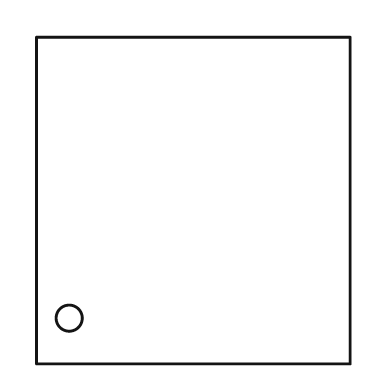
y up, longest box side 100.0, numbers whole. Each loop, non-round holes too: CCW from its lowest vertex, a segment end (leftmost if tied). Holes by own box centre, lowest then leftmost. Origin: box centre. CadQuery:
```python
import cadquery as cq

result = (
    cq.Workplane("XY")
    .moveTo(-48.0, -50.0)
    .lineTo(48.0, -50.0)
    .lineTo(48.0, 50.0)
    .lineTo(-48.0, 50.0)
    .close()
    .moveTo(-38.0, -36.0)
    .circle(4.0)
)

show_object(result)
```